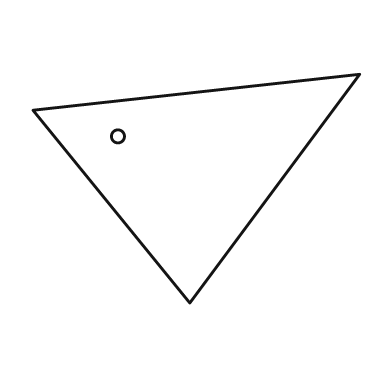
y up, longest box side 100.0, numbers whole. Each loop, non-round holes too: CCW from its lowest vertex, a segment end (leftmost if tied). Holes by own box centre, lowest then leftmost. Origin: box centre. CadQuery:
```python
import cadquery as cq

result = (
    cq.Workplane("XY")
    .moveTo(-2.0, -35.0)
    .lineTo(50.0, 35.0)
    .lineTo(-50.0, 24.0)
    .close()
    .moveTo(-24.0, 16.0)
    .circle(2.0)
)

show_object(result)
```